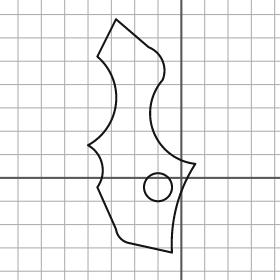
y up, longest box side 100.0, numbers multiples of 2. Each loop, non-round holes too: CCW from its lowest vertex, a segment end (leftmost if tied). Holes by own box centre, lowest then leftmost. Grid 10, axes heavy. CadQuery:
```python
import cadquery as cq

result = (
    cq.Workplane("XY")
    .moveTo(-4.0, -32.0)
    .threePointArc((-2.0, -12.0), (6.0, 6.0))
    .threePointArc((-12.0, 20.0), (-8.0, 42.0))
    .threePointArc((-8.0, 50.0), (-14.0, 56.0))
    .lineTo(-28.0, 68.0)
    .lineTo(-36.0, 52.0)
    .threePointArc((-28.0, 32.0), (-40.0, 14.0))
    .threePointArc((-34.0, 6.0), (-36.0, -4.0))
    .lineTo(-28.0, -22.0)
    .threePointArc((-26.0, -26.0), (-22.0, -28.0))
    .close()
    .moveTo(-10.0, -4.0)
    .circle(6.0)
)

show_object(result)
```